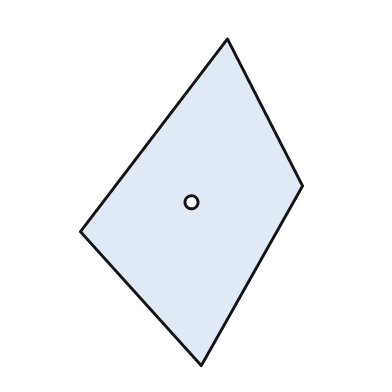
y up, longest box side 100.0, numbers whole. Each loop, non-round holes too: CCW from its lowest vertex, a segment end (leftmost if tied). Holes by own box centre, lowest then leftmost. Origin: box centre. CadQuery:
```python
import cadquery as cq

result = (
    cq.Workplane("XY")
    .moveTo(3.0, -50.0)
    .lineTo(34.0, 5.0)
    .lineTo(11.0, 50.0)
    .lineTo(-34.0, -9.0)
    .close()
    .moveTo(0.0, 0.0)
    .circle(2.0)
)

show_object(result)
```